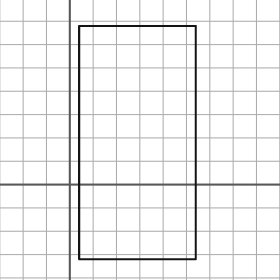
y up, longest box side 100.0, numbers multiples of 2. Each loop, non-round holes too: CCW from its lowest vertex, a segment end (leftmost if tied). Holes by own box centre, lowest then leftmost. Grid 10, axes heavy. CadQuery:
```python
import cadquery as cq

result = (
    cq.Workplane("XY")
    .moveTo(4.0, -32.0)
    .lineTo(54.0, -32.0)
    .lineTo(54.0, 68.0)
    .lineTo(4.0, 68.0)
    .close()
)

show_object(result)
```